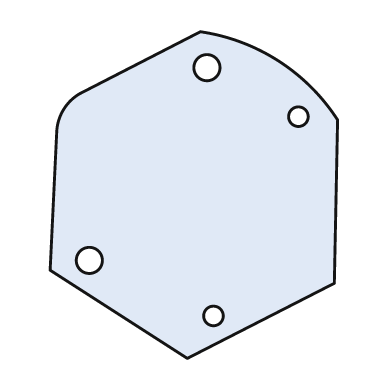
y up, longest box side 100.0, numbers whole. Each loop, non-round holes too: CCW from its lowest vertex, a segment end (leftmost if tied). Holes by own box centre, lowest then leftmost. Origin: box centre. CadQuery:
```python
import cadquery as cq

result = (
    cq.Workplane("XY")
    .moveTo(-2.0, -50.0)
    .lineTo(43.0, -27.0)
    .lineTo(44.0, 23.0)
    .threePointArc((26.0, 41.0), (2.0, 50.0))
    .lineTo(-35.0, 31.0)
    .threePointArc((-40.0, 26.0), (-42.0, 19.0))
    .lineTo(-44.0, -23.0)
    .close()
    .moveTo(6.0, -37.0)
    .circle(3.0)
    .moveTo(-32.0, -20.0)
    .circle(4.0)
    .moveTo(32.0, 24.0)
    .circle(3.0)
    .moveTo(4.0, 39.0)
    .circle(4.0)
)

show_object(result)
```